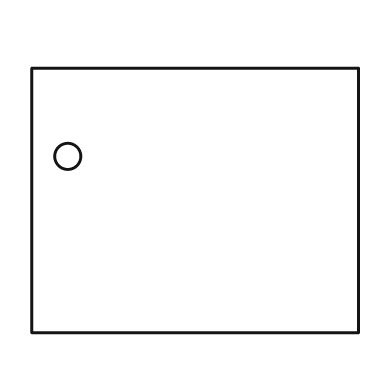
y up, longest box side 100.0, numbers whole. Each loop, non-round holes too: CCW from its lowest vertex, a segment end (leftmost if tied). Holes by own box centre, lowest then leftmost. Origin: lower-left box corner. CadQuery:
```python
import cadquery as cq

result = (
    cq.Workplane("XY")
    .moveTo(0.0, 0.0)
    .lineTo(100.0, 0.0)
    .lineTo(100.0, 81.0)
    .lineTo(0.0, 81.0)
    .close()
    .moveTo(11.0, 54.0)
    .circle(4.0)
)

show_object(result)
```